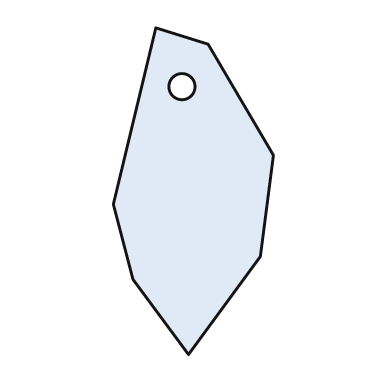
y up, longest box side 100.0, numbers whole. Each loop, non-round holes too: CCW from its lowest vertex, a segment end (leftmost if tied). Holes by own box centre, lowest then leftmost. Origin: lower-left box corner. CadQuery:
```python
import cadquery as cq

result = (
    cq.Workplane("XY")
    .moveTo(23.0, 0.0)
    .lineTo(45.0, 30.0)
    .lineTo(49.0, 61.0)
    .lineTo(29.0, 95.0)
    .lineTo(13.0, 100.0)
    .lineTo(0.0, 46.0)
    .lineTo(6.0, 23.0)
    .close()
    .moveTo(21.0, 82.0)
    .circle(4.0)
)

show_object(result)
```